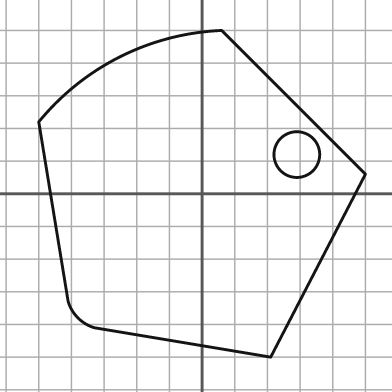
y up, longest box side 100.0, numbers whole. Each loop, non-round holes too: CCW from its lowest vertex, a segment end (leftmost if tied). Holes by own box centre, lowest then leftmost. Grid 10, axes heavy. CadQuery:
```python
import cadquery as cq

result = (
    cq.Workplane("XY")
    .moveTo(21.0, -50.0)
    .lineTo(50.0, 6.0)
    .lineTo(6.0, 50.0)
    .threePointArc((-25.0, 42.0), (-50.0, 22.0))
    .lineTo(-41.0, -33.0)
    .threePointArc((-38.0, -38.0), (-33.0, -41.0))
    .close()
    .moveTo(29.0, 12.0)
    .circle(7.0)
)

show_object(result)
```